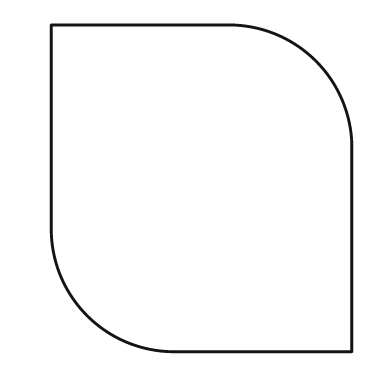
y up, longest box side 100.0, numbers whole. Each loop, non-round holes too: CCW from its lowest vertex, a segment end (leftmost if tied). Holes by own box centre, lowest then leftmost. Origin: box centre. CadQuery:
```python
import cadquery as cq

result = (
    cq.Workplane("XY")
    .moveTo(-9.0, -50.0)
    .lineTo(46.0, -50.0)
    .lineTo(46.0, 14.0)
    .threePointArc((35.0, 39.0), (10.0, 50.0))
    .lineTo(-46.0, 50.0)
    .lineTo(-46.0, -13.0)
    .threePointArc((-35.0, -39.0), (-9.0, -50.0))
    .close()
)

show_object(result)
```